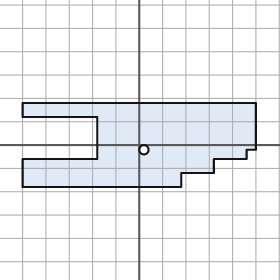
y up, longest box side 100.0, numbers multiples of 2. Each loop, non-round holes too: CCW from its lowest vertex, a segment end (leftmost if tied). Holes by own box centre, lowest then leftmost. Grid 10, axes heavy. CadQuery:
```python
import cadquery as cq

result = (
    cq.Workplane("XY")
    .moveTo(-50.0, -18.0)
    .lineTo(18.0, -18.0)
    .lineTo(18.0, -12.0)
    .lineTo(32.0, -12.0)
    .lineTo(32.0, -6.0)
    .lineTo(46.0, -6.0)
    .lineTo(46.0, -2.0)
    .lineTo(50.0, -2.0)
    .lineTo(50.0, 18.0)
    .lineTo(-50.0, 18.0)
    .lineTo(-50.0, 12.0)
    .lineTo(-18.0, 12.0)
    .lineTo(-18.0, -6.0)
    .lineTo(-50.0, -6.0)
    .close()
    .moveTo(2.0, -2.0)
    .circle(2.0)
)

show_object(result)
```